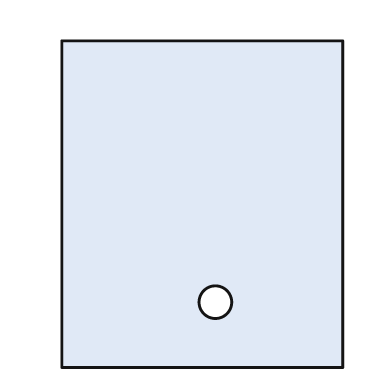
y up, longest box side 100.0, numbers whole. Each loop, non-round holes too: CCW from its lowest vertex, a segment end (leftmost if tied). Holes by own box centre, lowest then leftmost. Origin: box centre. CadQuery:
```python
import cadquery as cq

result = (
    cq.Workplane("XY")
    .moveTo(-43.0, -50.0)
    .lineTo(43.0, -50.0)
    .lineTo(43.0, 50.0)
    .lineTo(-43.0, 50.0)
    .close()
    .moveTo(4.0, -30.0)
    .circle(5.0)
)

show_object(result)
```